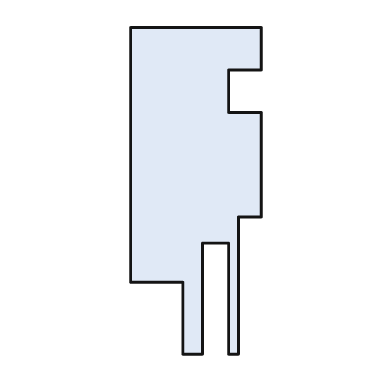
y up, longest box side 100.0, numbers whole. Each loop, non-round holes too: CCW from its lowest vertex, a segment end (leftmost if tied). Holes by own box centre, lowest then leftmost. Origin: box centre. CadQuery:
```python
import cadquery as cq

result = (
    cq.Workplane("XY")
    .moveTo(-4.0, -50.0)
    .lineTo(2.0, -50.0)
    .lineTo(2.0, -16.0)
    .lineTo(10.0, -16.0)
    .lineTo(10.0, -50.0)
    .lineTo(13.0, -50.0)
    .lineTo(13.0, -8.0)
    .lineTo(20.0, -8.0)
    .lineTo(20.0, 24.0)
    .lineTo(10.0, 24.0)
    .lineTo(10.0, 37.0)
    .lineTo(20.0, 37.0)
    .lineTo(20.0, 50.0)
    .lineTo(-20.0, 50.0)
    .lineTo(-20.0, -28.0)
    .lineTo(-4.0, -28.0)
    .close()
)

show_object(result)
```